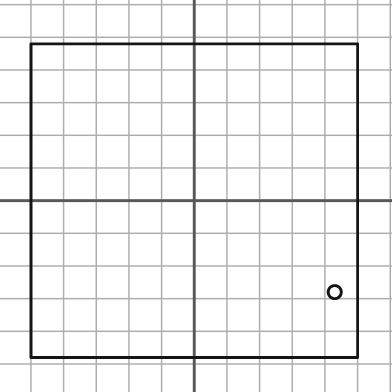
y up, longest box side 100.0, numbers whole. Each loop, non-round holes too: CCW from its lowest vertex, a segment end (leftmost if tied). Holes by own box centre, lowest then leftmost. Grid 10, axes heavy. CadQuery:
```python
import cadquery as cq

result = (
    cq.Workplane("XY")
    .moveTo(-50.0, -48.0)
    .lineTo(50.0, -48.0)
    .lineTo(50.0, 48.0)
    .lineTo(-50.0, 48.0)
    .close()
    .moveTo(43.0, -28.0)
    .circle(2.0)
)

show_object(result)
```